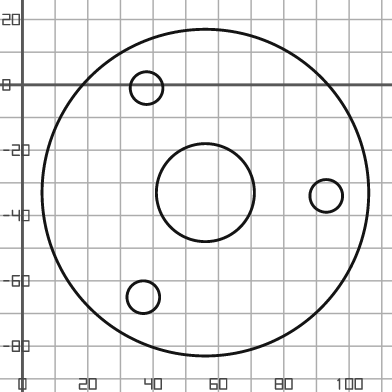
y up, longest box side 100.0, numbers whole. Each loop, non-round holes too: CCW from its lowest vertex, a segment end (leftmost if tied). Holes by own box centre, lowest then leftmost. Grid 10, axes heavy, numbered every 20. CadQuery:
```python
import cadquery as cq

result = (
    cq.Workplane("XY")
    .moveTo(56.0, -33.0)
    .circle(50.0)
    .moveTo(37.0, -65.0)
    .circle(5.0)
    .moveTo(93.0, -34.0)
    .circle(5.0)
    .moveTo(56.0, -33.0)
    .circle(15.0)
    .moveTo(38.0, -1.0)
    .circle(5.0)
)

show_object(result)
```